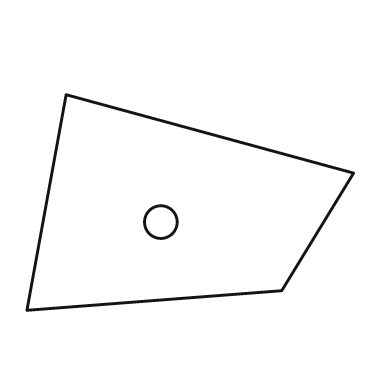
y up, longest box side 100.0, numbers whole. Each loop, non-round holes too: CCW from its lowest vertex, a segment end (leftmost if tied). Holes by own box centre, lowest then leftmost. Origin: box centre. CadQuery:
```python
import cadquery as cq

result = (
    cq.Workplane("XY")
    .moveTo(-50.0, -33.0)
    .lineTo(28.0, -27.0)
    .lineTo(50.0, 9.0)
    .lineTo(-38.0, 33.0)
    .close()
    .moveTo(-9.0, -6.0)
    .circle(5.0)
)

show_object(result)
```